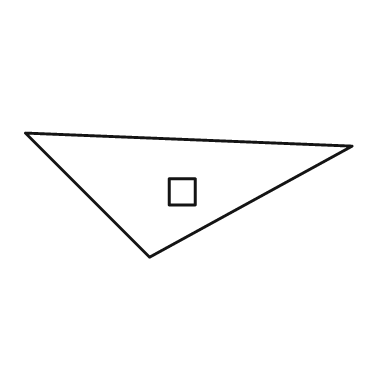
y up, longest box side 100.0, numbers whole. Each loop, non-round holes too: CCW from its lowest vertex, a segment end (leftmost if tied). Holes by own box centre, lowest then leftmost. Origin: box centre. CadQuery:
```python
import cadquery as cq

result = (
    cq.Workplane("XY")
    .moveTo(-12.0, -19.0)
    .lineTo(50.0, 15.0)
    .lineTo(-50.0, 19.0)
    .close()
    .moveTo(-6.0, -3.0)
    .lineTo(2.0, -3.0)
    .lineTo(2.0, 5.0)
    .lineTo(-6.0, 5.0)
    .close()
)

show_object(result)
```